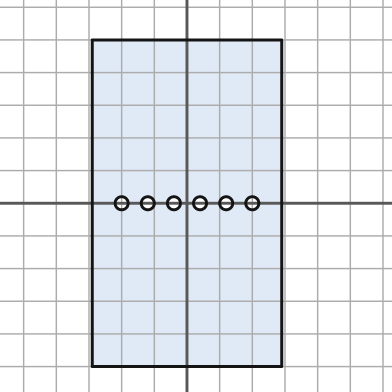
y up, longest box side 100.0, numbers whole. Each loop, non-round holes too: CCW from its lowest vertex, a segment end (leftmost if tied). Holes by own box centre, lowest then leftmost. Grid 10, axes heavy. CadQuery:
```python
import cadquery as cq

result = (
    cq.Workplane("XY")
    .moveTo(-29.0, -50.0)
    .lineTo(29.0, -50.0)
    .lineTo(29.0, 50.0)
    .lineTo(-29.0, 50.0)
    .close()
    .moveTo(-20.0, 0.0)
    .circle(2.0)
    .moveTo(-12.0, 0.0)
    .circle(2.0)
    .moveTo(-4.0, 0.0)
    .circle(2.0)
    .moveTo(4.0, 0.0)
    .circle(2.0)
    .moveTo(12.0, 0.0)
    .circle(2.0)
    .moveTo(20.0, 0.0)
    .circle(2.0)
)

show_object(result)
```